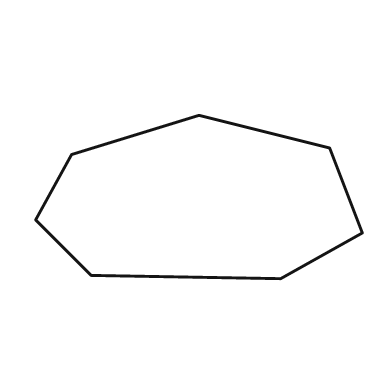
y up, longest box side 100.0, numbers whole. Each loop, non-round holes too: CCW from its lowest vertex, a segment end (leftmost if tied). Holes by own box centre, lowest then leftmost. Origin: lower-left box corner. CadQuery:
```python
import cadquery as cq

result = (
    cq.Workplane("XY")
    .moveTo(75.0, 0.0)
    .lineTo(100.0, 14.0)
    .lineTo(90.0, 40.0)
    .lineTo(50.0, 50.0)
    .lineTo(11.0, 38.0)
    .lineTo(0.0, 18.0)
    .lineTo(17.0, 1.0)
    .close()
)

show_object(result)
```